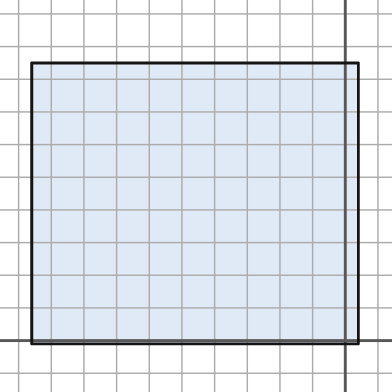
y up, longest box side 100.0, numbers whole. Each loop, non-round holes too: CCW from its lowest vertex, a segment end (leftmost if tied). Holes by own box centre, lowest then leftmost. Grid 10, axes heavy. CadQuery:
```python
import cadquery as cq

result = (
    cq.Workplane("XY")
    .moveTo(-96.0, -1.0)
    .lineTo(4.0, -1.0)
    .lineTo(4.0, 85.0)
    .lineTo(-96.0, 85.0)
    .close()
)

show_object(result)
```